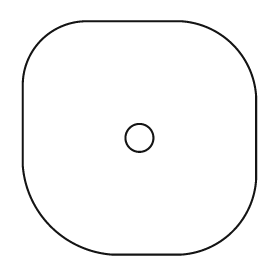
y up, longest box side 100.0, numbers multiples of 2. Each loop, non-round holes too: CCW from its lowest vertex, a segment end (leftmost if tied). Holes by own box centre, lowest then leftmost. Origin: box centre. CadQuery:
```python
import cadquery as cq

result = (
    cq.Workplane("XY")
    .moveTo(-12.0, -50.0)
    .lineTo(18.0, -50.0)
    .threePointArc((40.0, -40.0), (50.0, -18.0))
    .lineTo(50.0, 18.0)
    .threePointArc((40.0, 40.0), (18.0, 50.0))
    .lineTo(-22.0, 50.0)
    .threePointArc((-42.0, 42.0), (-50.0, 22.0))
    .lineTo(-50.0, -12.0)
    .threePointArc((-38.0, -38.0), (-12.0, -50.0))
    .close()
    .moveTo(0.0, 0.0)
    .circle(6.0)
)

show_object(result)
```